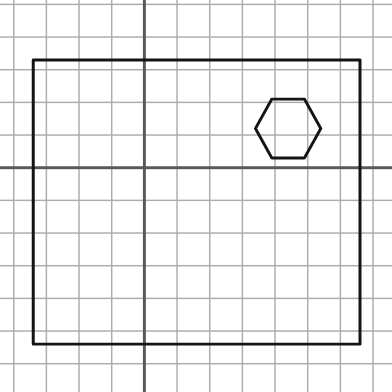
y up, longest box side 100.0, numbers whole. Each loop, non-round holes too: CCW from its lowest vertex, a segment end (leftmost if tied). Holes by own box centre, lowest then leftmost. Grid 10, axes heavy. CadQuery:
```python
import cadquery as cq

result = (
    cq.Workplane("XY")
    .moveTo(-34.0, -54.0)
    .lineTo(66.0, -54.0)
    .lineTo(66.0, 33.0)
    .lineTo(-34.0, 33.0)
    .close()
    .moveTo(39.0, 3.0)
    .lineTo(49.0, 3.0)
    .lineTo(54.0, 12.0)
    .lineTo(49.0, 21.0)
    .lineTo(39.0, 21.0)
    .lineTo(34.0, 12.0)
    .close()
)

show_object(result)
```